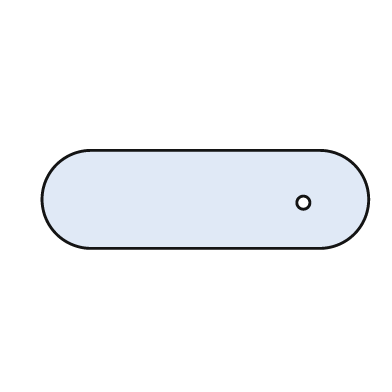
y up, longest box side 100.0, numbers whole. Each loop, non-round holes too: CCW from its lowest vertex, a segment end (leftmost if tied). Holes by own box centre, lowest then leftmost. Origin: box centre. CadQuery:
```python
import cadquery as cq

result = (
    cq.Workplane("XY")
    .moveTo(-35.0, -15.0)
    .lineTo(35.0, -15.0)
    .threePointArc((50.0, 0.0), (35.0, 15.0))
    .lineTo(-35.0, 15.0)
    .threePointArc((-50.0, 0.0), (-35.0, -15.0))
    .close()
    .moveTo(30.0, -1.0)
    .circle(2.0)
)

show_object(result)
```